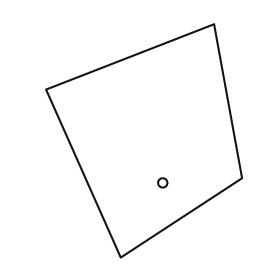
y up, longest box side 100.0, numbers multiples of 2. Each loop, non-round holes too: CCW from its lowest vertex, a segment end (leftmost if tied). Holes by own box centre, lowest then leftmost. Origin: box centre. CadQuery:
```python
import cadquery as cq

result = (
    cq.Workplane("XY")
    .moveTo(-10.0, -50.0)
    .lineTo(42.0, -16.0)
    .lineTo(30.0, 50.0)
    .lineTo(-42.0, 22.0)
    .close()
    .moveTo(8.0, -18.0)
    .circle(2.0)
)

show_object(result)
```